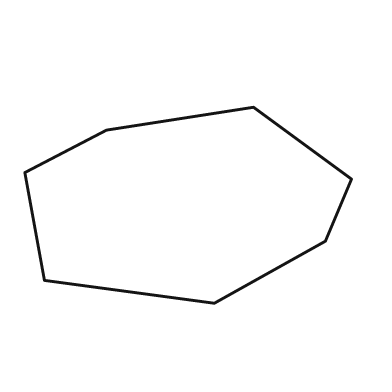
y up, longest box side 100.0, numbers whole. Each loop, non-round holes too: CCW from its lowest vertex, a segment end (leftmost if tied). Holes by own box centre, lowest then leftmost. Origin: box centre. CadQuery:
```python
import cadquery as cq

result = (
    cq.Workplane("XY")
    .moveTo(8.0, -30.0)
    .lineTo(42.0, -11.0)
    .lineTo(50.0, 8.0)
    .lineTo(20.0, 30.0)
    .lineTo(-25.0, 23.0)
    .lineTo(-50.0, 10.0)
    .lineTo(-44.0, -23.0)
    .close()
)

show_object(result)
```